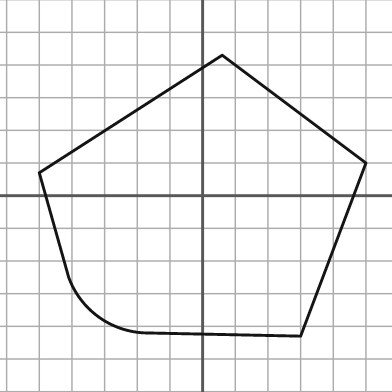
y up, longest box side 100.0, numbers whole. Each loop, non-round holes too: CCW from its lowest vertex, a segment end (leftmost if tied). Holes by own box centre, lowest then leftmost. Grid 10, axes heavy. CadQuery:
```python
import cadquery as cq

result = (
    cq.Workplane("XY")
    .moveTo(30.0, -43.0)
    .lineTo(50.0, 10.0)
    .lineTo(6.0, 43.0)
    .lineTo(-50.0, 7.0)
    .lineTo(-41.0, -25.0)
    .threePointArc((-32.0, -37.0), (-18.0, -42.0))
    .close()
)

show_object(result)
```